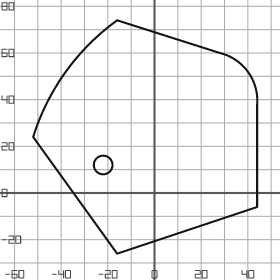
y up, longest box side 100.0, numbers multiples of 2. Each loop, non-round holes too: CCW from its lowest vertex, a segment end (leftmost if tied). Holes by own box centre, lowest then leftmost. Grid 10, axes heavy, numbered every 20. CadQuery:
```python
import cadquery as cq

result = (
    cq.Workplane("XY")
    .moveTo(-16.0, -26.0)
    .lineTo(44.0, -6.0)
    .lineTo(44.0, 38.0)
    .threePointArc((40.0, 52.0), (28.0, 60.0))
    .lineTo(-16.0, 74.0)
    .threePointArc((-38.0, 52.0), (-52.0, 24.0))
    .close()
    .moveTo(-22.0, 12.0)
    .circle(4.0)
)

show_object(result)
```